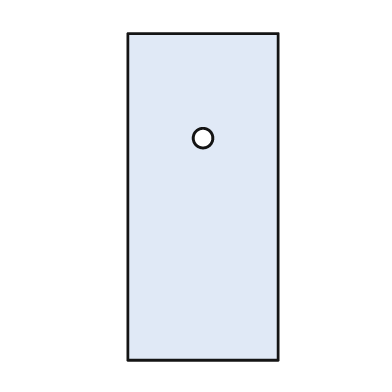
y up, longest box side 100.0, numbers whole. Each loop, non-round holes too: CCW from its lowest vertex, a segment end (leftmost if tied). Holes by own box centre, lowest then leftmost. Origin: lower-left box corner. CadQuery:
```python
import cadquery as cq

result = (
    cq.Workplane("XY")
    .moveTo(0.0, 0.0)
    .lineTo(46.0, 0.0)
    .lineTo(46.0, 100.0)
    .lineTo(0.0, 100.0)
    .close()
    .moveTo(23.0, 68.0)
    .circle(3.0)
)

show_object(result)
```